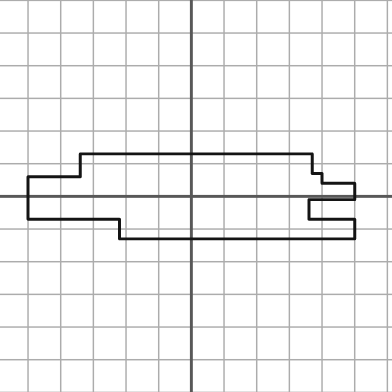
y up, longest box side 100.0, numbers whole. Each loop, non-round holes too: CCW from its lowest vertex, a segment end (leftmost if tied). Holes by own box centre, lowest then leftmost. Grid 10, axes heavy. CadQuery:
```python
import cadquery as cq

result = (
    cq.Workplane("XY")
    .moveTo(-22.0, -13.0)
    .lineTo(50.0, -13.0)
    .lineTo(50.0, -7.0)
    .lineTo(36.0, -7.0)
    .lineTo(36.0, -1.0)
    .lineTo(50.0, -1.0)
    .lineTo(50.0, 4.0)
    .lineTo(40.0, 4.0)
    .lineTo(40.0, 7.0)
    .lineTo(37.0, 7.0)
    .lineTo(37.0, 13.0)
    .lineTo(-34.0, 13.0)
    .lineTo(-34.0, 6.0)
    .lineTo(-50.0, 6.0)
    .lineTo(-50.0, -7.0)
    .lineTo(-22.0, -7.0)
    .close()
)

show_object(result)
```